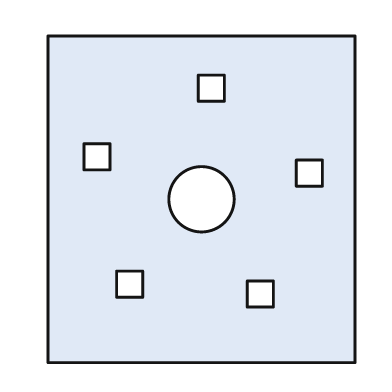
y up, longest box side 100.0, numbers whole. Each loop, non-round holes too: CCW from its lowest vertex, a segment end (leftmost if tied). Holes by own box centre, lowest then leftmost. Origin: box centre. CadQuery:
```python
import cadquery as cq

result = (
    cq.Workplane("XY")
    .moveTo(-47.0, -50.0)
    .lineTo(47.0, -50.0)
    .lineTo(47.0, 50.0)
    .lineTo(-47.0, 50.0)
    .close()
    .moveTo(14.0, -33.0)
    .lineTo(22.0, -33.0)
    .lineTo(22.0, -25.0)
    .lineTo(14.0, -25.0)
    .close()
    .moveTo(-26.0, -30.0)
    .lineTo(-18.0, -30.0)
    .lineTo(-18.0, -22.0)
    .lineTo(-26.0, -22.0)
    .close()
    .moveTo(0.0, 0.0)
    .circle(10.0)
    .moveTo(29.0, 4.0)
    .lineTo(37.0, 4.0)
    .lineTo(37.0, 12.0)
    .lineTo(29.0, 12.0)
    .close()
    .moveTo(-36.0, 9.0)
    .lineTo(-28.0, 9.0)
    .lineTo(-28.0, 17.0)
    .lineTo(-36.0, 17.0)
    .close()
    .moveTo(-1.0, 30.0)
    .lineTo(7.0, 30.0)
    .lineTo(7.0, 38.0)
    .lineTo(-1.0, 38.0)
    .close()
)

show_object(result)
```